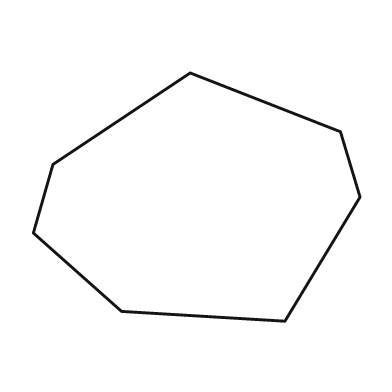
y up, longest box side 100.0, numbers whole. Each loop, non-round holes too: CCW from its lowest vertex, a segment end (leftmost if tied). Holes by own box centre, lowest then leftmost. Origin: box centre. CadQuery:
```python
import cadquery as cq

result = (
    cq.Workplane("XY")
    .moveTo(27.0, -38.0)
    .lineTo(50.0, 0.0)
    .lineTo(44.0, 20.0)
    .lineTo(-2.0, 38.0)
    .lineTo(-44.0, 10.0)
    .lineTo(-50.0, -11.0)
    .lineTo(-23.0, -35.0)
    .close()
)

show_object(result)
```